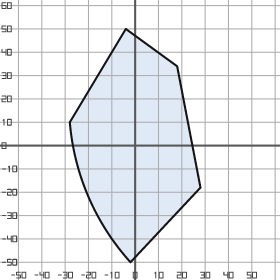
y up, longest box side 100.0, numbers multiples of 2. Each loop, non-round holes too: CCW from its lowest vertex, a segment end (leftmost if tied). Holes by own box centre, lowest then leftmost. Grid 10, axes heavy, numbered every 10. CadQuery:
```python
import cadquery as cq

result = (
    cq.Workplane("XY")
    .moveTo(-2.0, -50.0)
    .lineTo(28.0, -18.0)
    .lineTo(18.0, 34.0)
    .lineTo(-4.0, 50.0)
    .lineTo(-28.0, 10.0)
    .threePointArc((-20.0, -22.0), (-2.0, -50.0))
    .close()
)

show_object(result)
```